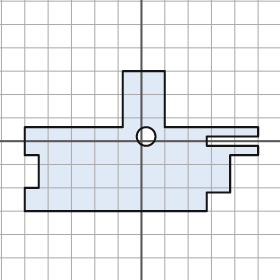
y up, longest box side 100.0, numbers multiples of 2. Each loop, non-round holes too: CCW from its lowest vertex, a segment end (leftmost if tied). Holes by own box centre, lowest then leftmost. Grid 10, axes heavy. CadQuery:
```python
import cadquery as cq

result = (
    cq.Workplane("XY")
    .moveTo(-50.0, -30.0)
    .lineTo(28.0, -30.0)
    .lineTo(28.0, -22.0)
    .lineTo(38.0, -22.0)
    .lineTo(38.0, -6.0)
    .lineTo(50.0, -6.0)
    .lineTo(50.0, -2.0)
    .lineTo(28.0, -2.0)
    .lineTo(28.0, 2.0)
    .lineTo(50.0, 2.0)
    .lineTo(50.0, 6.0)
    .lineTo(10.0, 6.0)
    .lineTo(10.0, 30.0)
    .lineTo(-8.0, 30.0)
    .lineTo(-8.0, 6.0)
    .lineTo(-50.0, 6.0)
    .lineTo(-50.0, -6.0)
    .lineTo(-44.0, -6.0)
    .lineTo(-44.0, -20.0)
    .lineTo(-50.0, -20.0)
    .close()
    .moveTo(2.0, 2.0)
    .circle(4.0)
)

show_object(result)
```